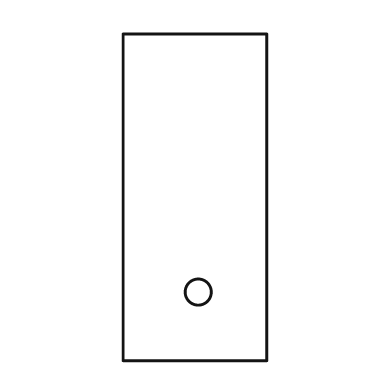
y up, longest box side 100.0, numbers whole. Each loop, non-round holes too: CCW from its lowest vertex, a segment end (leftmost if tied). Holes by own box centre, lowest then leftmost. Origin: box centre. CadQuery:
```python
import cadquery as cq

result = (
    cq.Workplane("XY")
    .moveTo(-22.0, -50.0)
    .lineTo(22.0, -50.0)
    .lineTo(22.0, 50.0)
    .lineTo(-22.0, 50.0)
    .close()
    .moveTo(1.0, -29.0)
    .circle(4.0)
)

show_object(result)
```